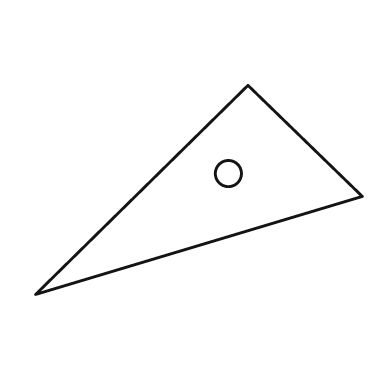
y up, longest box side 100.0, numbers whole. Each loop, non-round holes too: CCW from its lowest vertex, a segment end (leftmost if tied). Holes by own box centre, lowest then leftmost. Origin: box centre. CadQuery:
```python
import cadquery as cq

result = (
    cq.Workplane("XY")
    .moveTo(-50.0, -32.0)
    .lineTo(50.0, -2.0)
    .lineTo(15.0, 32.0)
    .close()
    .moveTo(9.0, 5.0)
    .circle(4.0)
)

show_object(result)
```